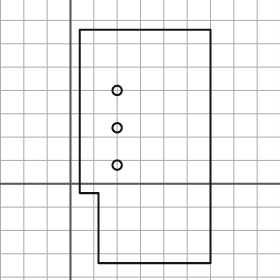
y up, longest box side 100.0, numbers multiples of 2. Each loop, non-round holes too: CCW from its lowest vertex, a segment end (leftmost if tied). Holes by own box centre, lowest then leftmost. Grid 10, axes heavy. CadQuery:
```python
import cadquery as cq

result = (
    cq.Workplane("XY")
    .moveTo(12.0, -34.0)
    .lineTo(60.0, -34.0)
    .lineTo(60.0, 66.0)
    .lineTo(4.0, 66.0)
    .lineTo(4.0, -4.0)
    .lineTo(12.0, -4.0)
    .close()
    .moveTo(20.0, 8.0)
    .circle(2.0)
    .moveTo(20.0, 24.0)
    .circle(2.0)
    .moveTo(20.0, 40.0)
    .circle(2.0)
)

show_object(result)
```